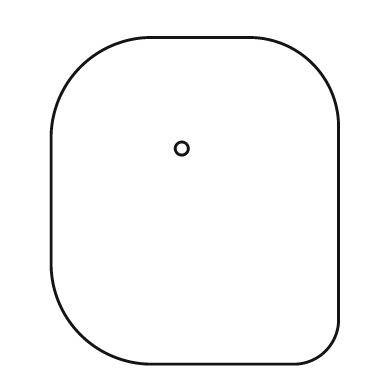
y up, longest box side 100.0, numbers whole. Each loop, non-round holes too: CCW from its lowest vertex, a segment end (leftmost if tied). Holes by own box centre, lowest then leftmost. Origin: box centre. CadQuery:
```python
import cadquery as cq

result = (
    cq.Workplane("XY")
    .moveTo(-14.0, -50.0)
    .lineTo(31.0, -50.0)
    .threePointArc((40.0, -46.0), (44.0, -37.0))
    .lineTo(44.0, 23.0)
    .threePointArc((36.0, 42.0), (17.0, 50.0))
    .lineTo(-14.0, 50.0)
    .threePointArc((-35.0, 41.0), (-44.0, 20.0))
    .lineTo(-44.0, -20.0)
    .threePointArc((-35.0, -41.0), (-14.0, -50.0))
    .close()
    .moveTo(-4.0, 16.0)
    .circle(2.0)
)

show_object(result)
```